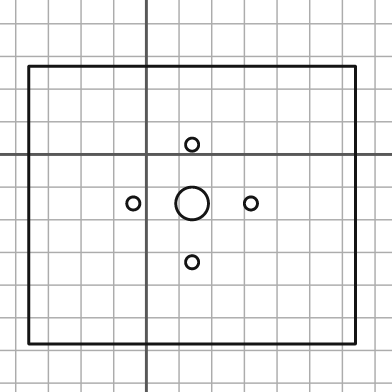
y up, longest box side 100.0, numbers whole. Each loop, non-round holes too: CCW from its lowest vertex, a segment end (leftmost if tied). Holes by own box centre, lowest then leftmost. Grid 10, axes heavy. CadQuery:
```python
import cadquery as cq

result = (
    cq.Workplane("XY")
    .moveTo(-36.0, -58.0)
    .lineTo(64.0, -58.0)
    .lineTo(64.0, 27.0)
    .lineTo(-36.0, 27.0)
    .close()
    .moveTo(14.0, -33.0)
    .circle(2.0)
    .moveTo(-4.0, -15.0)
    .circle(2.0)
    .moveTo(14.0, -15.0)
    .circle(5.0)
    .moveTo(32.0, -15.0)
    .circle(2.0)
    .moveTo(14.0, 3.0)
    .circle(2.0)
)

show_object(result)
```